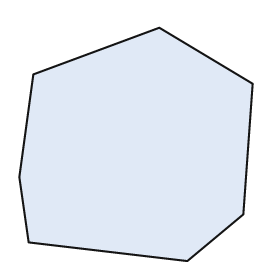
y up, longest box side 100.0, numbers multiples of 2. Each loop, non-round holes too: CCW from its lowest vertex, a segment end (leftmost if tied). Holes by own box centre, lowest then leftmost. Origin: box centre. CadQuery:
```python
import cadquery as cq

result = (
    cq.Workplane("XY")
    .moveTo(22.0, -50.0)
    .lineTo(46.0, -30.0)
    .lineTo(50.0, 26.0)
    .lineTo(10.0, 50.0)
    .lineTo(-44.0, 30.0)
    .lineTo(-50.0, -14.0)
    .lineTo(-46.0, -42.0)
    .close()
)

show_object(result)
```